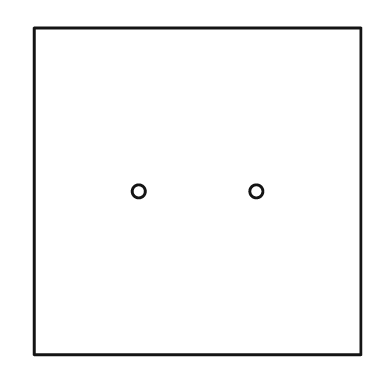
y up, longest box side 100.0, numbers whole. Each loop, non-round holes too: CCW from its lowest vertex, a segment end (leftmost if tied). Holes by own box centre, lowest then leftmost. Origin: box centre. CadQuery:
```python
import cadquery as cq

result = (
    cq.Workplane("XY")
    .moveTo(-50.0, -50.0)
    .lineTo(50.0, -50.0)
    .lineTo(50.0, 50.0)
    .lineTo(-50.0, 50.0)
    .close()
    .moveTo(-18.0, 0.0)
    .circle(2.0)
    .moveTo(18.0, 0.0)
    .circle(2.0)
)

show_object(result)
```